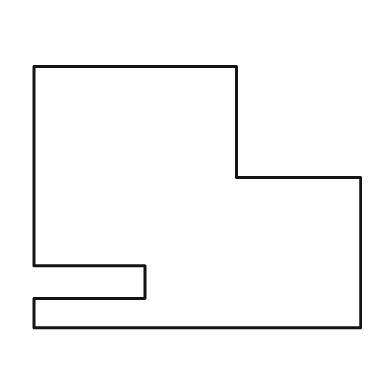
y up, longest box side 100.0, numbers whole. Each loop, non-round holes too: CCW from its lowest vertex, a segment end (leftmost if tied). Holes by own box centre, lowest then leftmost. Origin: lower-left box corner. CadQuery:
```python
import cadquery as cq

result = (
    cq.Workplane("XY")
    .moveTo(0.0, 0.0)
    .lineTo(100.0, 0.0)
    .lineTo(100.0, 46.0)
    .lineTo(62.0, 46.0)
    .lineTo(62.0, 80.0)
    .lineTo(0.0, 80.0)
    .lineTo(0.0, 19.0)
    .lineTo(34.0, 19.0)
    .lineTo(34.0, 9.0)
    .lineTo(0.0, 9.0)
    .close()
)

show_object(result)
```